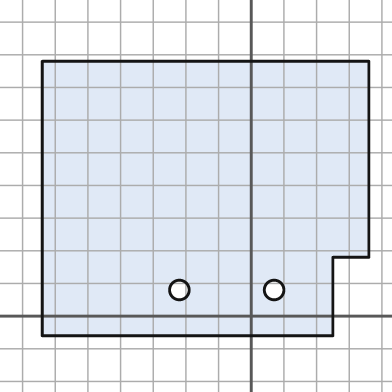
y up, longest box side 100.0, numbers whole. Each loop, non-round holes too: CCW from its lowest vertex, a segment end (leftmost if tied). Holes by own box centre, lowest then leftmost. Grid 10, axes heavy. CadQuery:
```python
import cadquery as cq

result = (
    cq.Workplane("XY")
    .moveTo(-64.0, -6.0)
    .lineTo(25.0, -6.0)
    .lineTo(25.0, 18.0)
    .lineTo(36.0, 18.0)
    .lineTo(36.0, 78.0)
    .lineTo(-64.0, 78.0)
    .close()
    .moveTo(-22.0, 8.0)
    .circle(3.0)
    .moveTo(7.0, 8.0)
    .circle(3.0)
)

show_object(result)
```